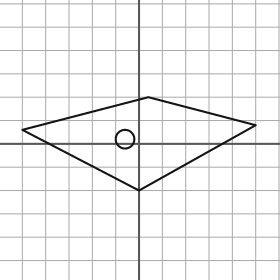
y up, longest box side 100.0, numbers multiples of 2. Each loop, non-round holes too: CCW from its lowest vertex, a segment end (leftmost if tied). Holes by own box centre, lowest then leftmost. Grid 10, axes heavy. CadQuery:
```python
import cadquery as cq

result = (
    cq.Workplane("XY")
    .moveTo(0.0, -20.0)
    .lineTo(50.0, 8.0)
    .lineTo(4.0, 20.0)
    .lineTo(-50.0, 6.0)
    .close()
    .moveTo(-6.0, 2.0)
    .circle(4.0)
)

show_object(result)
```